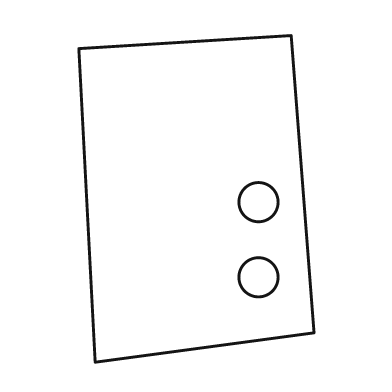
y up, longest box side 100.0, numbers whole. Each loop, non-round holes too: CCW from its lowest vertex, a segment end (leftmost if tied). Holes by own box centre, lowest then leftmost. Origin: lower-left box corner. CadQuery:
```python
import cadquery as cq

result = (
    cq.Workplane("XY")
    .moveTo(5.0, 0.0)
    .lineTo(72.0, 9.0)
    .lineTo(65.0, 100.0)
    .lineTo(0.0, 96.0)
    .close()
    .moveTo(55.0, 26.0)
    .circle(6.0)
    .moveTo(55.0, 49.0)
    .circle(6.0)
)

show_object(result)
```